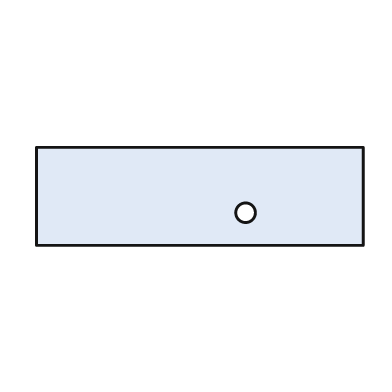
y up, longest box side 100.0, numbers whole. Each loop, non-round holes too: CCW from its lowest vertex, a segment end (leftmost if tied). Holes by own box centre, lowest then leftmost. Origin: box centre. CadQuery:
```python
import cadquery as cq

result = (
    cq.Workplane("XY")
    .moveTo(-50.0, -15.0)
    .lineTo(50.0, -15.0)
    .lineTo(50.0, 15.0)
    .lineTo(-50.0, 15.0)
    .close()
    .moveTo(14.0, -5.0)
    .circle(3.0)
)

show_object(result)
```